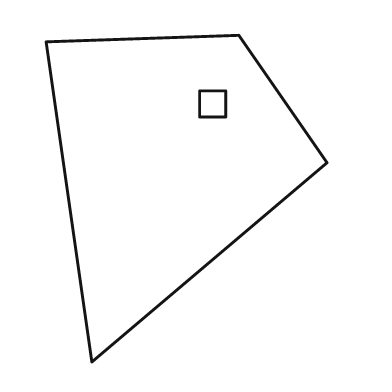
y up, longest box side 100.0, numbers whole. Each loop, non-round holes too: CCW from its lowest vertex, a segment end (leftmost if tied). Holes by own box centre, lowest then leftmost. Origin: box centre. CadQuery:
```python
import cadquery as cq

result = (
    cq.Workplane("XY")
    .moveTo(-29.0, -50.0)
    .lineTo(43.0, 11.0)
    .lineTo(16.0, 50.0)
    .lineTo(-43.0, 48.0)
    .close()
    .moveTo(4.0, 25.0)
    .lineTo(12.0, 25.0)
    .lineTo(12.0, 33.0)
    .lineTo(4.0, 33.0)
    .close()
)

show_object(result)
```